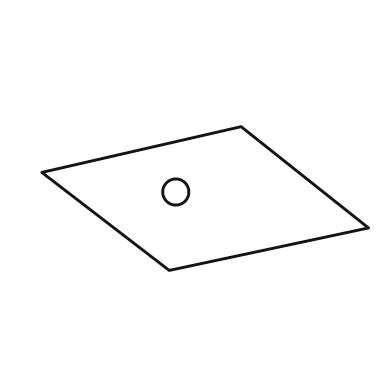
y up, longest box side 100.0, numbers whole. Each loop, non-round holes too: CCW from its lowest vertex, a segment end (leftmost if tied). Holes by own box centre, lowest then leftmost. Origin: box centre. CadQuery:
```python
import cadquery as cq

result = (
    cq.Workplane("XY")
    .moveTo(-11.0, -22.0)
    .lineTo(50.0, -9.0)
    .lineTo(11.0, 22.0)
    .lineTo(-50.0, 8.0)
    .close()
    .moveTo(-9.0, 2.0)
    .circle(4.0)
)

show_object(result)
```